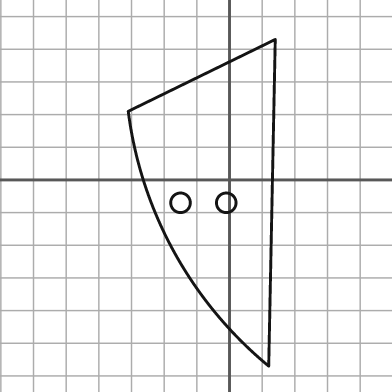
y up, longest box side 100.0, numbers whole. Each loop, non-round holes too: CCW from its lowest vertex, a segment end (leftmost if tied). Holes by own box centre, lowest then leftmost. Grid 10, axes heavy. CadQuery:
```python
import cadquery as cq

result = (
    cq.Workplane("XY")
    .moveTo(12.0, -57.0)
    .lineTo(14.0, 43.0)
    .lineTo(-31.0, 21.0)
    .threePointArc((-17.0, -22.0), (12.0, -57.0))
    .close()
    .moveTo(-15.0, -7.0)
    .circle(3.0)
    .moveTo(-1.0, -7.0)
    .circle(3.0)
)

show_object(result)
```